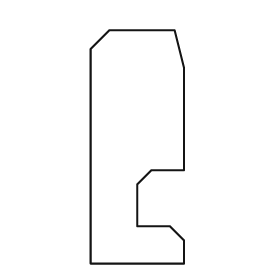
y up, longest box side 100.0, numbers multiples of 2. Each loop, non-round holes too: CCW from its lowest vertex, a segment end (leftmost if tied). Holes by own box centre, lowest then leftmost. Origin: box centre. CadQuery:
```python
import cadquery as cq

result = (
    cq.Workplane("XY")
    .moveTo(-20.0, -50.0)
    .lineTo(20.0, -50.0)
    .lineTo(20.0, -40.0)
    .lineTo(14.0, -34.0)
    .lineTo(0.0, -34.0)
    .lineTo(0.0, -16.0)
    .lineTo(6.0, -10.0)
    .lineTo(20.0, -10.0)
    .lineTo(20.0, 34.0)
    .lineTo(16.0, 50.0)
    .lineTo(-12.0, 50.0)
    .lineTo(-20.0, 42.0)
    .close()
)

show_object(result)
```